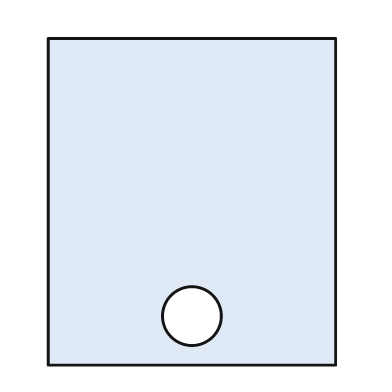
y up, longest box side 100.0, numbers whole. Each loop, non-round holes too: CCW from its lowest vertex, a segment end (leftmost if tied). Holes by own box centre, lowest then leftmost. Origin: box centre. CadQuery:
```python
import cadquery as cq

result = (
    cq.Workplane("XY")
    .moveTo(-44.0, -50.0)
    .lineTo(44.0, -50.0)
    .lineTo(44.0, 50.0)
    .lineTo(-44.0, 50.0)
    .close()
    .moveTo(0.0, -35.0)
    .circle(9.0)
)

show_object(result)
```